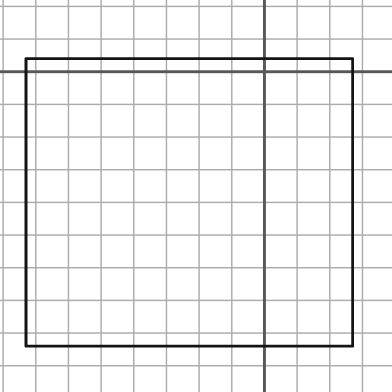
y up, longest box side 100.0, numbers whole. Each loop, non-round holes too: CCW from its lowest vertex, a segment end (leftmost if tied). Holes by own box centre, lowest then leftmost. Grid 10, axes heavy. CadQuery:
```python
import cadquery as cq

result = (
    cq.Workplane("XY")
    .moveTo(-73.0, -84.0)
    .lineTo(27.0, -84.0)
    .lineTo(27.0, 4.0)
    .lineTo(-73.0, 4.0)
    .close()
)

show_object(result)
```